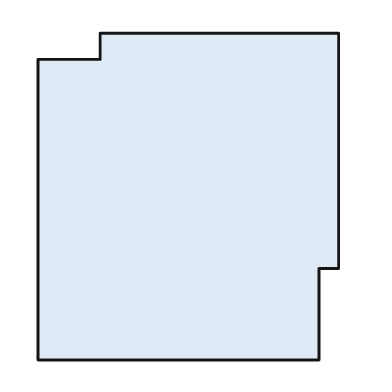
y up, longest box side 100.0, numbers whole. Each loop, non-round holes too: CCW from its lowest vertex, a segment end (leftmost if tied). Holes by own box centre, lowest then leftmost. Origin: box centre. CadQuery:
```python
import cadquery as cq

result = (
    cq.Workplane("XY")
    .moveTo(-46.0, -50.0)
    .lineTo(40.0, -50.0)
    .lineTo(40.0, -22.0)
    .lineTo(46.0, -22.0)
    .lineTo(46.0, 50.0)
    .lineTo(-27.0, 50.0)
    .lineTo(-27.0, 42.0)
    .lineTo(-46.0, 42.0)
    .close()
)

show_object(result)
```